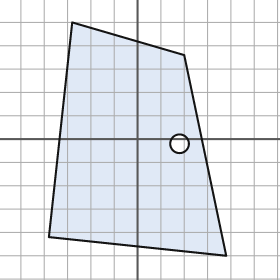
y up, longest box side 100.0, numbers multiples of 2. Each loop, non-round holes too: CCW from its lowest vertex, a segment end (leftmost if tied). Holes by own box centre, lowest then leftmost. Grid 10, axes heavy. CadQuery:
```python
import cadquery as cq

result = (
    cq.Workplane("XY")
    .moveTo(38.0, -50.0)
    .lineTo(20.0, 36.0)
    .lineTo(-28.0, 50.0)
    .lineTo(-38.0, -42.0)
    .close()
    .moveTo(18.0, -2.0)
    .circle(4.0)
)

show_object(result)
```